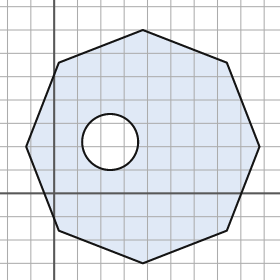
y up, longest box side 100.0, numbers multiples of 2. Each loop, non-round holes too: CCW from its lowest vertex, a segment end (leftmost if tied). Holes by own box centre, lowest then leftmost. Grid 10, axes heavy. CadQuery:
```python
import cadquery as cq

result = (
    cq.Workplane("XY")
    .moveTo(38.0, -30.0)
    .lineTo(74.0, -16.0)
    .lineTo(88.0, 20.0)
    .lineTo(74.0, 56.0)
    .lineTo(38.0, 70.0)
    .lineTo(2.0, 56.0)
    .lineTo(-12.0, 20.0)
    .lineTo(2.0, -16.0)
    .close()
    .moveTo(24.0, 22.0)
    .circle(12.0)
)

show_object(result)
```